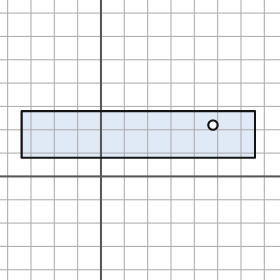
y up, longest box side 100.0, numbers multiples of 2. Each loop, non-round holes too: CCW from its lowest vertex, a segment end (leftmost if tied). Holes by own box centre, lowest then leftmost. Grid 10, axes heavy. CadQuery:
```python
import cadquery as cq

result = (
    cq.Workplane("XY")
    .moveTo(-34.0, 8.0)
    .lineTo(66.0, 8.0)
    .lineTo(66.0, 28.0)
    .lineTo(-34.0, 28.0)
    .close()
    .moveTo(48.0, 22.0)
    .circle(2.0)
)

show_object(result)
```